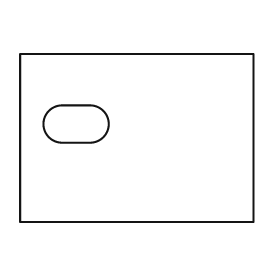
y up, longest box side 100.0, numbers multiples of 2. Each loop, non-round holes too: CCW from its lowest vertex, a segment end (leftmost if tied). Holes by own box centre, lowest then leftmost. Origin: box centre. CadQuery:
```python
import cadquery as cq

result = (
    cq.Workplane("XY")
    .moveTo(-50.0, -36.0)
    .lineTo(50.0, -36.0)
    .lineTo(50.0, 36.0)
    .lineTo(-50.0, 36.0)
    .close()
    .moveTo(-32.0, -2.0)
    .lineTo(-20.0, -2.0)
    .threePointArc((-12.0, 6.0), (-20.0, 14.0))
    .lineTo(-32.0, 14.0)
    .threePointArc((-40.0, 6.0), (-32.0, -2.0))
    .close()
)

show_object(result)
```